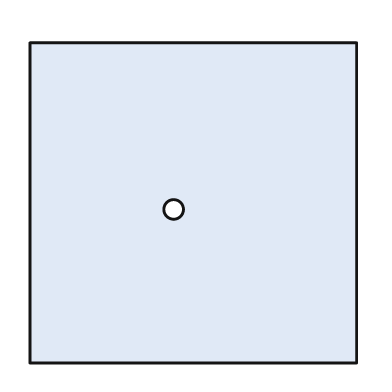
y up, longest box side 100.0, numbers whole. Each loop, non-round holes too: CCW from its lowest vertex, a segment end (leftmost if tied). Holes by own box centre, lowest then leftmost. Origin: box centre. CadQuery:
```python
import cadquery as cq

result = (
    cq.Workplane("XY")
    .moveTo(-50.0, -49.0)
    .lineTo(50.0, -49.0)
    .lineTo(50.0, 49.0)
    .lineTo(-50.0, 49.0)
    .close()
    .moveTo(-6.0, -2.0)
    .circle(3.0)
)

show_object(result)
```